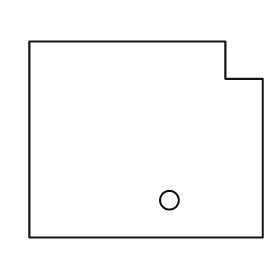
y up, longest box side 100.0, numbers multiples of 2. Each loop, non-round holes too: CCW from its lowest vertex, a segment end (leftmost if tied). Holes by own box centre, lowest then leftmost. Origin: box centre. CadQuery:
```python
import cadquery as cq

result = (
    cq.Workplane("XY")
    .moveTo(-50.0, -42.0)
    .lineTo(50.0, -42.0)
    .lineTo(50.0, 26.0)
    .lineTo(34.0, 26.0)
    .lineTo(34.0, 42.0)
    .lineTo(-50.0, 42.0)
    .close()
    .moveTo(10.0, -26.0)
    .circle(4.0)
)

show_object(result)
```